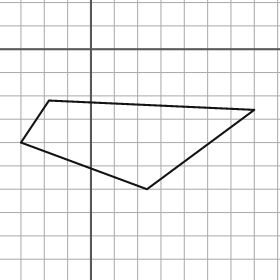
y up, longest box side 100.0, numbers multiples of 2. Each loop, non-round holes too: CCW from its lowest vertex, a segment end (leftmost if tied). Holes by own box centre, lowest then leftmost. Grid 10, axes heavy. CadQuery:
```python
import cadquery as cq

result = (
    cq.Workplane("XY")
    .moveTo(24.0, -60.0)
    .lineTo(70.0, -26.0)
    .lineTo(-18.0, -22.0)
    .lineTo(-30.0, -40.0)
    .close()
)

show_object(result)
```